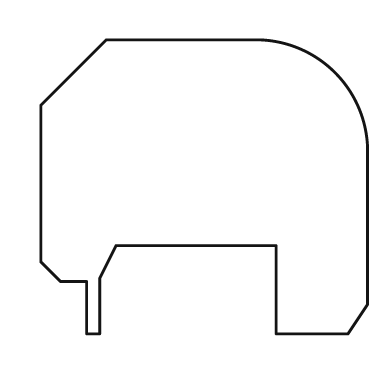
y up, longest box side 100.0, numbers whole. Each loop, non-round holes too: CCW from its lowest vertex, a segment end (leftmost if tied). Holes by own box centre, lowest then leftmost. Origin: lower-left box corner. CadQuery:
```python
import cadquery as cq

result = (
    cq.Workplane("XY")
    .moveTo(14.0, 0.0)
    .lineTo(18.0, 0.0)
    .lineTo(18.0, 17.0)
    .lineTo(23.0, 27.0)
    .lineTo(72.0, 27.0)
    .lineTo(72.0, 0.0)
    .lineTo(94.0, 0.0)
    .lineTo(100.0, 9.0)
    .lineTo(100.0, 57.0)
    .threePointArc((90.0, 80.0), (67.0, 90.0))
    .lineTo(20.0, 90.0)
    .lineTo(0.0, 70.0)
    .lineTo(0.0, 22.0)
    .lineTo(6.0, 16.0)
    .lineTo(14.0, 16.0)
    .close()
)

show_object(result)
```